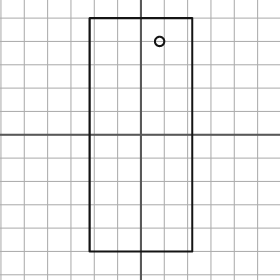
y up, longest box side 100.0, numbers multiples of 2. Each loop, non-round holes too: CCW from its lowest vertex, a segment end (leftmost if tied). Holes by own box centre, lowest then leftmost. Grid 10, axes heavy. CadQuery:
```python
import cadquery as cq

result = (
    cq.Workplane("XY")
    .moveTo(-22.0, -50.0)
    .lineTo(22.0, -50.0)
    .lineTo(22.0, 50.0)
    .lineTo(-22.0, 50.0)
    .close()
    .moveTo(8.0, 40.0)
    .circle(2.0)
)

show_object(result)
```